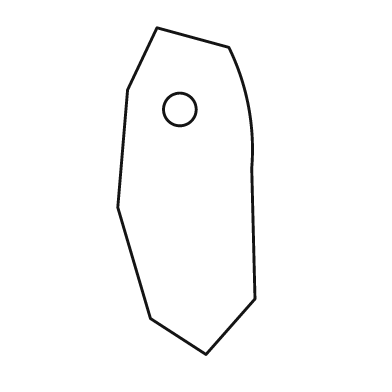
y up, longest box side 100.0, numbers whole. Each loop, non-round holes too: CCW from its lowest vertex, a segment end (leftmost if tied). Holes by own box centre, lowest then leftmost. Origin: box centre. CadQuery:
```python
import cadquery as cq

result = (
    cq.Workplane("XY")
    .moveTo(6.0, -50.0)
    .lineTo(21.0, -33.0)
    .lineTo(20.0, 7.0)
    .threePointArc((19.0, 26.0), (13.0, 44.0))
    .lineTo(-9.0, 50.0)
    .lineTo(-18.0, 31.0)
    .lineTo(-21.0, -5.0)
    .lineTo(-11.0, -39.0)
    .close()
    .moveTo(-2.0, 25.0)
    .circle(5.0)
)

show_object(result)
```